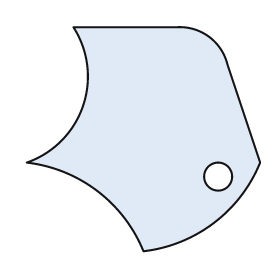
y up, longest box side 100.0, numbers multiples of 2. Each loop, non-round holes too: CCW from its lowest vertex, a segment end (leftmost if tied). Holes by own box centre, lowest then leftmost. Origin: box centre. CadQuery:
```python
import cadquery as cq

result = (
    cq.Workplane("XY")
    .moveTo(0.0, -48.0)
    .threePointArc((30.0, -36.0), (50.0, -10.0))
    .lineTo(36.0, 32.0)
    .threePointArc((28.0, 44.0), (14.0, 48.0))
    .lineTo(-30.0, 48.0)
    .threePointArc((-26.0, 14.0), (-50.0, -10.0))
    .threePointArc((-20.0, -22.0), (0.0, -48.0))
    .close()
    .moveTo(32.0, -16.0)
    .circle(6.0)
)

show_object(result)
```